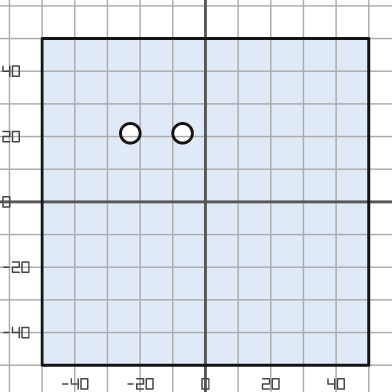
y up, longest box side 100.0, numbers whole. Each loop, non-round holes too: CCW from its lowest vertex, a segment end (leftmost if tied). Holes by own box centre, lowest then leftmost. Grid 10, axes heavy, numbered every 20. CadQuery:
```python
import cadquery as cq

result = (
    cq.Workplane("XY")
    .moveTo(-50.0, -50.0)
    .lineTo(50.0, -50.0)
    .lineTo(50.0, 50.0)
    .lineTo(-50.0, 50.0)
    .close()
    .moveTo(-23.0, 21.0)
    .circle(3.0)
    .moveTo(-7.0, 21.0)
    .circle(3.0)
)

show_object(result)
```